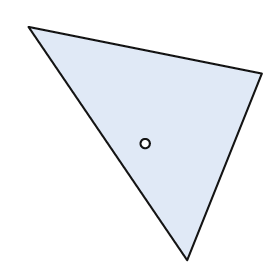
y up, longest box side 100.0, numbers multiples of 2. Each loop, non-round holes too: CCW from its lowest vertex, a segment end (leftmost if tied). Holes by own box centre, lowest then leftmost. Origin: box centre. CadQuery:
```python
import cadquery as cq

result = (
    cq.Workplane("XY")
    .moveTo(18.0, -50.0)
    .lineTo(50.0, 30.0)
    .lineTo(-50.0, 50.0)
    .close()
    .moveTo(0.0, 0.0)
    .circle(2.0)
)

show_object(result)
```